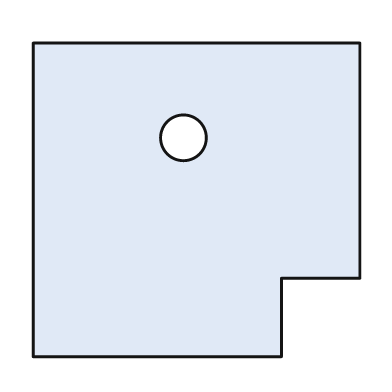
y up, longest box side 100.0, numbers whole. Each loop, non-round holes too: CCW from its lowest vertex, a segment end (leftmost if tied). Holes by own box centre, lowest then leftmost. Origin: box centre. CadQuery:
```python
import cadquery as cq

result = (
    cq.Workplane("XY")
    .moveTo(-50.0, -48.0)
    .lineTo(26.0, -48.0)
    .lineTo(26.0, -24.0)
    .lineTo(50.0, -24.0)
    .lineTo(50.0, 48.0)
    .lineTo(-50.0, 48.0)
    .close()
    .moveTo(-4.0, 19.0)
    .circle(7.0)
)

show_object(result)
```